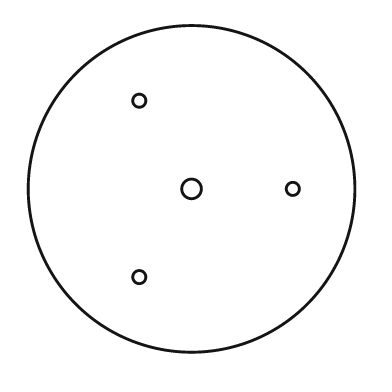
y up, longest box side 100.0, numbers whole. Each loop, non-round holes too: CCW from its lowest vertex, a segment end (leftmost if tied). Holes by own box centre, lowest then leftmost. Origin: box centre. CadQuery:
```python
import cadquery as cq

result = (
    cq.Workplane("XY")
    .moveTo(0.0, 0.0)
    .circle(50.0)
    .moveTo(-16.0, -27.0)
    .circle(2.0)
    .moveTo(0.0, 0.0)
    .circle(3.0)
    .moveTo(31.0, 0.0)
    .circle(2.0)
    .moveTo(-16.0, 27.0)
    .circle(2.0)
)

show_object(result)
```